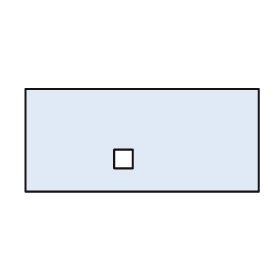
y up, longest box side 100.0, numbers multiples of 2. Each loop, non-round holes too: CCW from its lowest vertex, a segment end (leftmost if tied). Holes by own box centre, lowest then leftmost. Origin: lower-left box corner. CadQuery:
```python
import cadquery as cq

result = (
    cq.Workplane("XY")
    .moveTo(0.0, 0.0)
    .lineTo(100.0, 0.0)
    .lineTo(100.0, 44.0)
    .lineTo(0.0, 44.0)
    .close()
    .moveTo(38.0, 10.0)
    .lineTo(46.0, 10.0)
    .lineTo(46.0, 18.0)
    .lineTo(38.0, 18.0)
    .close()
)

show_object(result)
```